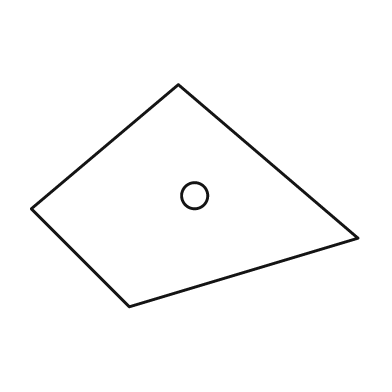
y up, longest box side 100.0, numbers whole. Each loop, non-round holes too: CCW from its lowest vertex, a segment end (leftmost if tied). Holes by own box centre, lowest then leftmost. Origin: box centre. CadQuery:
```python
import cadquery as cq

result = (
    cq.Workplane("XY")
    .moveTo(-20.0, -34.0)
    .lineTo(50.0, -13.0)
    .lineTo(-5.0, 34.0)
    .lineTo(-50.0, -4.0)
    .close()
    .moveTo(0.0, 0.0)
    .circle(4.0)
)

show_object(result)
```